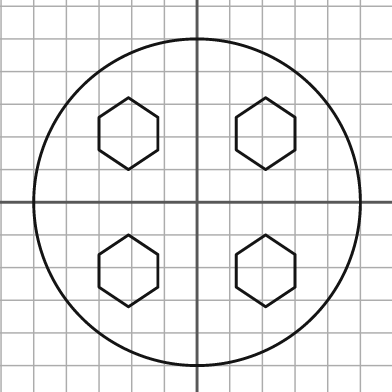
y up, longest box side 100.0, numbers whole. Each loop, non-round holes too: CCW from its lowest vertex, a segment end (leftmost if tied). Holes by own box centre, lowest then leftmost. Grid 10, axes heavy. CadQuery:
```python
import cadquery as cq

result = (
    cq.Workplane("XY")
    .moveTo(0.0, 0.0)
    .circle(50.0)
    .moveTo(-21.0, -32.0)
    .lineTo(-12.0, -26.0)
    .lineTo(-12.0, -16.0)
    .lineTo(-21.0, -10.0)
    .lineTo(-30.0, -16.0)
    .lineTo(-30.0, -26.0)
    .close()
    .moveTo(21.0, -32.0)
    .lineTo(30.0, -26.0)
    .lineTo(30.0, -16.0)
    .lineTo(21.0, -10.0)
    .lineTo(12.0, -16.0)
    .lineTo(12.0, -26.0)
    .close()
    .moveTo(-21.0, 10.0)
    .lineTo(-12.0, 16.0)
    .lineTo(-12.0, 26.0)
    .lineTo(-21.0, 32.0)
    .lineTo(-30.0, 26.0)
    .lineTo(-30.0, 16.0)
    .close()
    .moveTo(21.0, 10.0)
    .lineTo(30.0, 16.0)
    .lineTo(30.0, 26.0)
    .lineTo(21.0, 32.0)
    .lineTo(12.0, 26.0)
    .lineTo(12.0, 16.0)
    .close()
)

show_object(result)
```